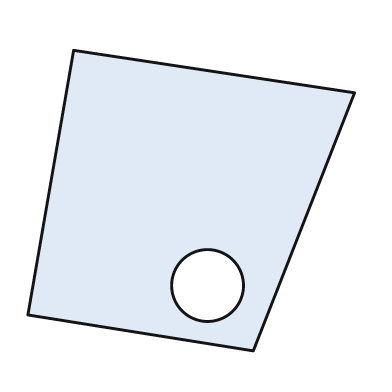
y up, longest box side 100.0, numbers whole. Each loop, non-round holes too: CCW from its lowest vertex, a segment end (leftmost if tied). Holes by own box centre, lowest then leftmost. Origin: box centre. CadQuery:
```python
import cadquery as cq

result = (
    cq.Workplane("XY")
    .moveTo(19.0, -46.0)
    .lineTo(50.0, 33.0)
    .lineTo(-36.0, 46.0)
    .lineTo(-50.0, -35.0)
    .close()
    .moveTo(5.0, -26.0)
    .circle(11.0)
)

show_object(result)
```